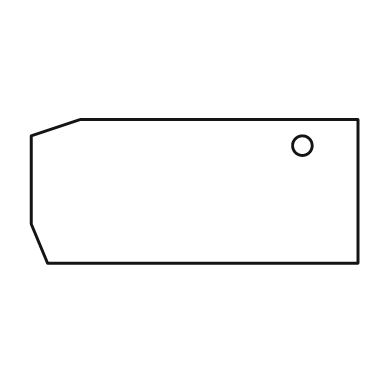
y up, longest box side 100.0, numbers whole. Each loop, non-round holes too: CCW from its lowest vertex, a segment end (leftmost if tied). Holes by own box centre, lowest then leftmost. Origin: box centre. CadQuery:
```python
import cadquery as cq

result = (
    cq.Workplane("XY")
    .moveTo(-45.0, -22.0)
    .lineTo(50.0, -22.0)
    .lineTo(50.0, 22.0)
    .lineTo(-35.0, 22.0)
    .lineTo(-50.0, 17.0)
    .lineTo(-50.0, -10.0)
    .close()
    .moveTo(33.0, 14.0)
    .circle(3.0)
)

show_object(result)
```